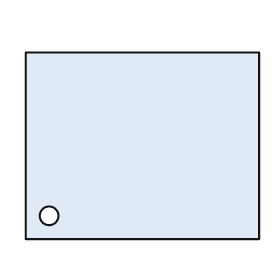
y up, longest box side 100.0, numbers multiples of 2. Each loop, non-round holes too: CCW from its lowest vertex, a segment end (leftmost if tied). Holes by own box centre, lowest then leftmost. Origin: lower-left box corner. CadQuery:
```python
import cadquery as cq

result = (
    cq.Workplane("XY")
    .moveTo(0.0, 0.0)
    .lineTo(100.0, 0.0)
    .lineTo(100.0, 80.0)
    .lineTo(0.0, 80.0)
    .close()
    .moveTo(10.0, 10.0)
    .circle(4.0)
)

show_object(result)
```